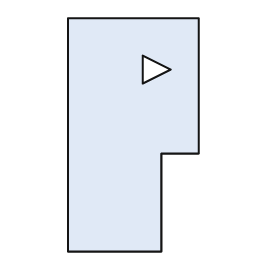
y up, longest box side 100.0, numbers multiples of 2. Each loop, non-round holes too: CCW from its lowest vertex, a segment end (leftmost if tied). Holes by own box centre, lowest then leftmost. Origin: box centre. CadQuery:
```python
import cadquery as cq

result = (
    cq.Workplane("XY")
    .moveTo(-28.0, -50.0)
    .lineTo(12.0, -50.0)
    .lineTo(12.0, -8.0)
    .lineTo(28.0, -8.0)
    .lineTo(28.0, 50.0)
    .lineTo(-28.0, 50.0)
    .close()
    .moveTo(4.0, 22.0)
    .lineTo(16.0, 28.0)
    .lineTo(4.0, 34.0)
    .close()
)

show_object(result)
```